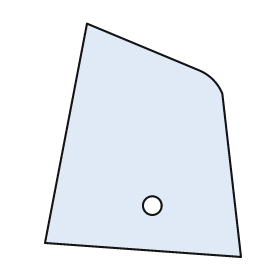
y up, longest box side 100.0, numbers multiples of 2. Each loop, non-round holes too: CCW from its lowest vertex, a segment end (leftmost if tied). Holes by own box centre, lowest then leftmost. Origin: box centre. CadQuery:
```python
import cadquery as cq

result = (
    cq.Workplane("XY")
    .moveTo(42.0, -50.0)
    .lineTo(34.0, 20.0)
    .threePointArc((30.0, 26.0), (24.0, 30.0))
    .lineTo(-24.0, 50.0)
    .lineTo(-42.0, -44.0)
    .close()
    .moveTo(4.0, -28.0)
    .circle(4.0)
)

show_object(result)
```